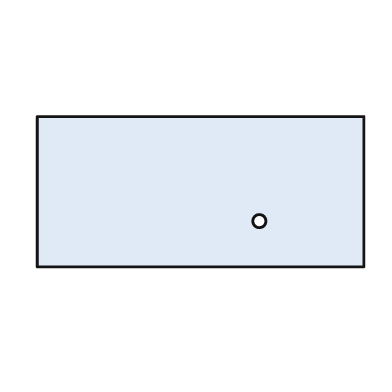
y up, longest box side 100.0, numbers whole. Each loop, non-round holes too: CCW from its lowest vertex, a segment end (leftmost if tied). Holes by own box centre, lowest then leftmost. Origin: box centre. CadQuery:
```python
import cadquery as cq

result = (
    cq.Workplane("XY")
    .moveTo(-50.0, -23.0)
    .lineTo(50.0, -23.0)
    .lineTo(50.0, 23.0)
    .lineTo(-50.0, 23.0)
    .close()
    .moveTo(18.0, -9.0)
    .circle(2.0)
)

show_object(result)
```